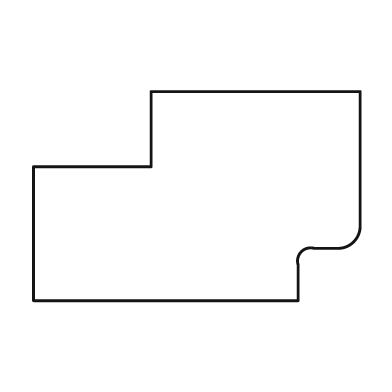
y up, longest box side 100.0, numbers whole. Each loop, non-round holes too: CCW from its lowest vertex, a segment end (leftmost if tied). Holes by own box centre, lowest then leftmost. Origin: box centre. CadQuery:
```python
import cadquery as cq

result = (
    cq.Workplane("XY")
    .moveTo(-50.0, -32.0)
    .lineTo(31.0, -32.0)
    .lineTo(31.0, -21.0)
    .threePointArc((32.0, -17.0), (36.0, -16.0))
    .lineTo(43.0, -16.0)
    .threePointArc((48.0, -14.0), (50.0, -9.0))
    .lineTo(50.0, 32.0)
    .lineTo(-14.0, 32.0)
    .lineTo(-14.0, 9.0)
    .lineTo(-50.0, 9.0)
    .close()
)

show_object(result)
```